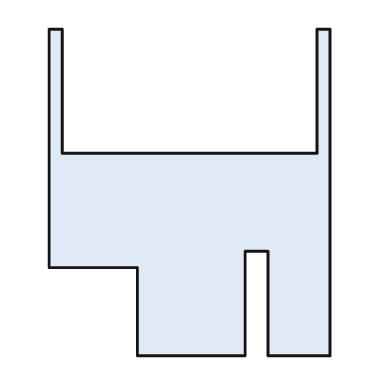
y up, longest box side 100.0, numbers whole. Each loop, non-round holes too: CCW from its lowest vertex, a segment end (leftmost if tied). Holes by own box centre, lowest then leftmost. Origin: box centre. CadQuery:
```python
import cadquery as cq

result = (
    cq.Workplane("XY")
    .moveTo(-16.0, -50.0)
    .lineTo(17.0, -50.0)
    .lineTo(17.0, -18.0)
    .lineTo(24.0, -18.0)
    .lineTo(24.0, -50.0)
    .lineTo(43.0, -50.0)
    .lineTo(43.0, 50.0)
    .lineTo(39.0, 50.0)
    .lineTo(39.0, 12.0)
    .lineTo(-39.0, 12.0)
    .lineTo(-39.0, 50.0)
    .lineTo(-43.0, 50.0)
    .lineTo(-43.0, -23.0)
    .lineTo(-16.0, -23.0)
    .close()
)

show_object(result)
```